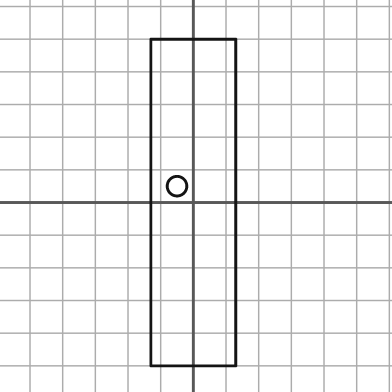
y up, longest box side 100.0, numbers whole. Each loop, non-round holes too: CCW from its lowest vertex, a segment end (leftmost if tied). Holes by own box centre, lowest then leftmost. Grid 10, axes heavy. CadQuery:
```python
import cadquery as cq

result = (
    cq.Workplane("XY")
    .moveTo(-13.0, -50.0)
    .lineTo(13.0, -50.0)
    .lineTo(13.0, 50.0)
    .lineTo(-13.0, 50.0)
    .close()
    .moveTo(-5.0, 5.0)
    .circle(3.0)
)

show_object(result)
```